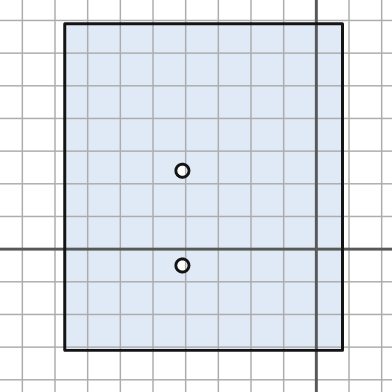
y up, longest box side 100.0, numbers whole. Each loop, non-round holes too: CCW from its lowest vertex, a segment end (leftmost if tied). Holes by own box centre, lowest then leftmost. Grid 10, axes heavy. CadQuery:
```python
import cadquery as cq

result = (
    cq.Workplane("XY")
    .moveTo(-77.0, -31.0)
    .lineTo(8.0, -31.0)
    .lineTo(8.0, 69.0)
    .lineTo(-77.0, 69.0)
    .close()
    .moveTo(-41.0, -5.0)
    .circle(2.0)
    .moveTo(-41.0, 24.0)
    .circle(2.0)
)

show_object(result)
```